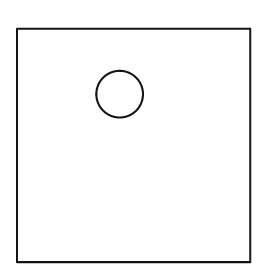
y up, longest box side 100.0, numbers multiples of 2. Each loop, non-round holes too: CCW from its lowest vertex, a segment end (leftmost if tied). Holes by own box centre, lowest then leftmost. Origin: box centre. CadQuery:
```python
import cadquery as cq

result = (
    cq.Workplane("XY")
    .moveTo(-50.0, -50.0)
    .lineTo(50.0, -50.0)
    .lineTo(50.0, 50.0)
    .lineTo(-50.0, 50.0)
    .close()
    .moveTo(-6.0, 22.0)
    .circle(10.0)
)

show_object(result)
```